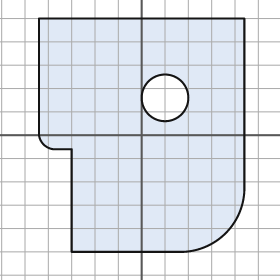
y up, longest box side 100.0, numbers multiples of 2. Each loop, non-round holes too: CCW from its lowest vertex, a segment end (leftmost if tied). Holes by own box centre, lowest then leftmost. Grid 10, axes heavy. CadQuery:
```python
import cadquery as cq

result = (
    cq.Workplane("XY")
    .moveTo(-30.0, -50.0)
    .lineTo(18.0, -50.0)
    .threePointArc((36.0, -42.0), (44.0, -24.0))
    .lineTo(44.0, 50.0)
    .lineTo(-44.0, 50.0)
    .lineTo(-44.0, 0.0)
    .threePointArc((-42.0, -4.0), (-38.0, -6.0))
    .lineTo(-30.0, -6.0)
    .close()
    .moveTo(10.0, 16.0)
    .circle(10.0)
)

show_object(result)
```